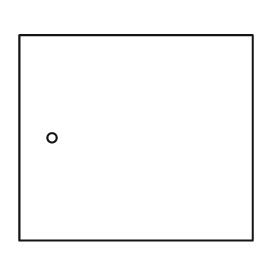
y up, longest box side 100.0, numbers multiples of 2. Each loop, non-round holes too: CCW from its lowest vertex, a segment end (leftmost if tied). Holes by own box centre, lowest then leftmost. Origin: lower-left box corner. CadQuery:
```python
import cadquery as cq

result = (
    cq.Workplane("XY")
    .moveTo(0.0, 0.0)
    .lineTo(100.0, 0.0)
    .lineTo(100.0, 88.0)
    .lineTo(0.0, 88.0)
    .close()
    .moveTo(14.0, 44.0)
    .circle(2.0)
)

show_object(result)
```